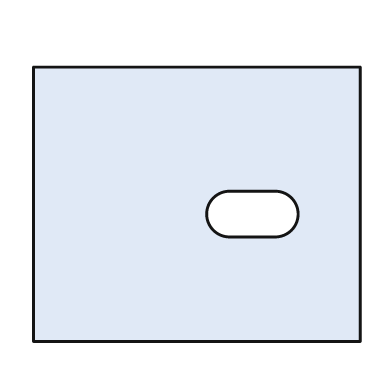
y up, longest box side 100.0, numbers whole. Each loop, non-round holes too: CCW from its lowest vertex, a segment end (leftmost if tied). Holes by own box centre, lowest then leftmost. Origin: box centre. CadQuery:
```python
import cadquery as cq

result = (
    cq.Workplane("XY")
    .moveTo(-50.0, -42.0)
    .lineTo(50.0, -42.0)
    .lineTo(50.0, 42.0)
    .lineTo(-50.0, 42.0)
    .close()
    .moveTo(10.0, -10.0)
    .lineTo(24.0, -10.0)
    .threePointArc((31.0, -3.0), (24.0, 4.0))
    .lineTo(10.0, 4.0)
    .threePointArc((3.0, -3.0), (10.0, -10.0))
    .close()
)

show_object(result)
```